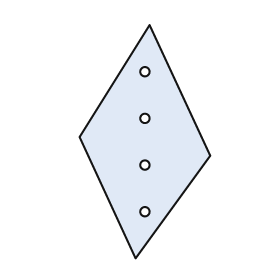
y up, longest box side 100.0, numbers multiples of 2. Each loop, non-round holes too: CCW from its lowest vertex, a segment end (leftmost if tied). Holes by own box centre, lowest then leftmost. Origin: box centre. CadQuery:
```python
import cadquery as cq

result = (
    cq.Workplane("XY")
    .moveTo(-4.0, -50.0)
    .lineTo(28.0, -6.0)
    .lineTo(2.0, 50.0)
    .lineTo(-28.0, 2.0)
    .close()
    .moveTo(0.0, -30.0)
    .circle(2.0)
    .moveTo(0.0, -10.0)
    .circle(2.0)
    .moveTo(0.0, 10.0)
    .circle(2.0)
    .moveTo(0.0, 30.0)
    .circle(2.0)
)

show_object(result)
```